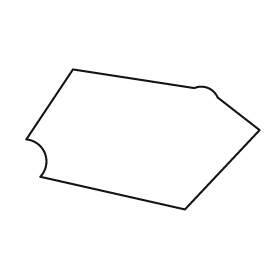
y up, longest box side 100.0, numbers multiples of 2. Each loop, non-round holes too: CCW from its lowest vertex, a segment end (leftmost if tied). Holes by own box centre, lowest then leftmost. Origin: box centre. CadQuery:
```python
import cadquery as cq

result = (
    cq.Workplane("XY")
    .moveTo(18.0, -30.0)
    .lineTo(50.0, 4.0)
    .lineTo(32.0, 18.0)
    .threePointArc((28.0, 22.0), (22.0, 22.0))
    .lineTo(-30.0, 30.0)
    .lineTo(-50.0, 0.0)
    .threePointArc((-42.0, -6.0), (-44.0, -16.0))
    .close()
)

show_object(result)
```